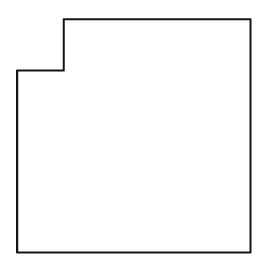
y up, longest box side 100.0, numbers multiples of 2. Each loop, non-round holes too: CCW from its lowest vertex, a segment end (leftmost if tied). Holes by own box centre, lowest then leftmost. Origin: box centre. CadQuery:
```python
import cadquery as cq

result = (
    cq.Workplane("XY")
    .moveTo(-50.0, -50.0)
    .lineTo(50.0, -50.0)
    .lineTo(50.0, 50.0)
    .lineTo(-30.0, 50.0)
    .lineTo(-30.0, 28.0)
    .lineTo(-50.0, 28.0)
    .close()
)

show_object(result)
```